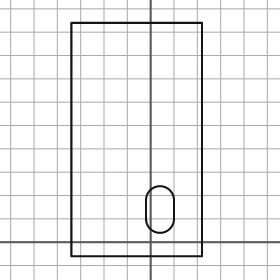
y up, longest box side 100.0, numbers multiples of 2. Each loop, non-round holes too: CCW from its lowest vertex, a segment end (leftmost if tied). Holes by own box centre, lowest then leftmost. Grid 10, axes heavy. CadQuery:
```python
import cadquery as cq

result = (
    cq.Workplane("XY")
    .moveTo(-34.0, -6.0)
    .lineTo(22.0, -6.0)
    .lineTo(22.0, 94.0)
    .lineTo(-34.0, 94.0)
    .close()
    .moveTo(-2.0, 10.0)
    .threePointArc((4.0, 4.0), (10.0, 10.0))
    .lineTo(10.0, 18.0)
    .threePointArc((4.0, 24.0), (-2.0, 18.0))
    .close()
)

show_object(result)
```